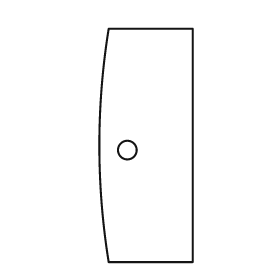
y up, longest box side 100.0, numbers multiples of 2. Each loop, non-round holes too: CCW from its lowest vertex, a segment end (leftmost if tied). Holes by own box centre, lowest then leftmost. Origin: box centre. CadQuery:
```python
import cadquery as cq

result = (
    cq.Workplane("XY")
    .moveTo(-16.0, -50.0)
    .lineTo(20.0, -50.0)
    .lineTo(20.0, 50.0)
    .lineTo(-16.0, 50.0)
    .threePointArc((-20.0, 0.0), (-16.0, -50.0))
    .close()
    .moveTo(-8.0, -2.0)
    .circle(4.0)
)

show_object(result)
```